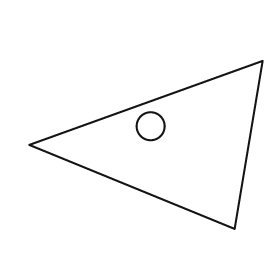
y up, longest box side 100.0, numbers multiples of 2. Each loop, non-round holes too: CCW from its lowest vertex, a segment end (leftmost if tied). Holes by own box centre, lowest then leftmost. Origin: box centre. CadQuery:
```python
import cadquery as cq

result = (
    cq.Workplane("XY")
    .moveTo(38.0, -36.0)
    .lineTo(50.0, 36.0)
    .lineTo(-50.0, 0.0)
    .close()
    .moveTo(2.0, 8.0)
    .circle(6.0)
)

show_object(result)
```